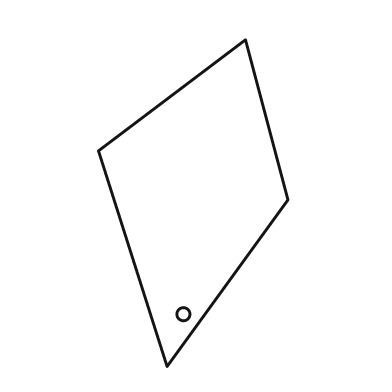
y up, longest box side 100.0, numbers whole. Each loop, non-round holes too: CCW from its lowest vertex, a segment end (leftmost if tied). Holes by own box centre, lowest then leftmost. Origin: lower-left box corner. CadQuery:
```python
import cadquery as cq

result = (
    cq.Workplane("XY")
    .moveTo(21.0, 0.0)
    .lineTo(58.0, 51.0)
    .lineTo(45.0, 100.0)
    .lineTo(0.0, 66.0)
    .close()
    .moveTo(26.0, 16.0)
    .circle(2.0)
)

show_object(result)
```